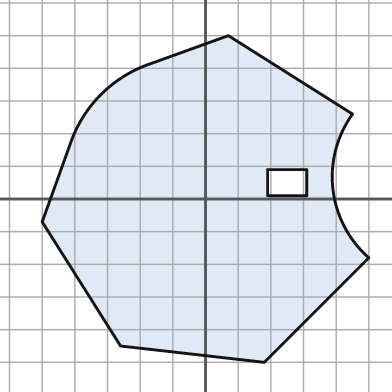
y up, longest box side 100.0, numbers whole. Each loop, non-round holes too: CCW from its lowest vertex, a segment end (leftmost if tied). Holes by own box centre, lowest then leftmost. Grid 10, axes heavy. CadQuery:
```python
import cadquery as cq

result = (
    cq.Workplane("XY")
    .moveTo(18.0, -50.0)
    .lineTo(50.0, -18.0)
    .threePointArc((39.0, 3.0), (45.0, 26.0))
    .lineTo(7.0, 50.0)
    .lineTo(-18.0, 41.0)
    .threePointArc((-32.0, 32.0), (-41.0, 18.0))
    .lineTo(-50.0, -7.0)
    .lineTo(-26.0, -45.0)
    .close()
    .moveTo(19.0, 1.0)
    .lineTo(31.0, 1.0)
    .lineTo(31.0, 9.0)
    .lineTo(19.0, 9.0)
    .close()
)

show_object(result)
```